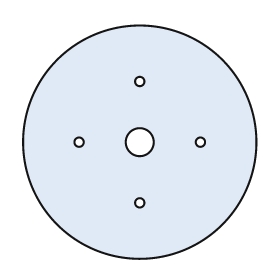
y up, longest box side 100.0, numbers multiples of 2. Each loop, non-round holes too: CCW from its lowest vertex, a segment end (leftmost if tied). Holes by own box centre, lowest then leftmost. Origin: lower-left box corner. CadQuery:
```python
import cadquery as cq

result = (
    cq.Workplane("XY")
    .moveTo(50.0, 50.0)
    .circle(50.0)
    .moveTo(50.0, 24.0)
    .circle(2.0)
    .moveTo(24.0, 50.0)
    .circle(2.0)
    .moveTo(50.0, 50.0)
    .circle(6.0)
    .moveTo(76.0, 50.0)
    .circle(2.0)
    .moveTo(50.0, 76.0)
    .circle(2.0)
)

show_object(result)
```